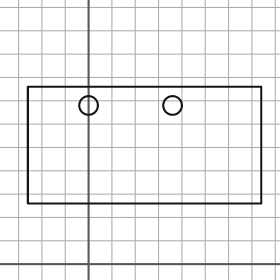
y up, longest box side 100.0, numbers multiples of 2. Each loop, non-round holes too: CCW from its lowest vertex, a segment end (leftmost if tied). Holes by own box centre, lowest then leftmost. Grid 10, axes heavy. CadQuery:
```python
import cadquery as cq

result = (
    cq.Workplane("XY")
    .moveTo(-26.0, 26.0)
    .lineTo(74.0, 26.0)
    .lineTo(74.0, 76.0)
    .lineTo(-26.0, 76.0)
    .close()
    .moveTo(0.0, 68.0)
    .circle(4.0)
    .moveTo(36.0, 68.0)
    .circle(4.0)
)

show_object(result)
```